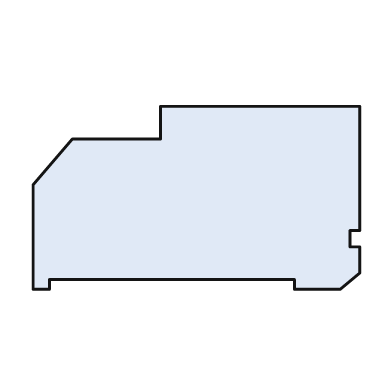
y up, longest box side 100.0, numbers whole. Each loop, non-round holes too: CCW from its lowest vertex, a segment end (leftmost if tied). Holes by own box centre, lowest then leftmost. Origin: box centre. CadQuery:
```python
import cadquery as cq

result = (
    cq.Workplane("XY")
    .moveTo(-50.0, -28.0)
    .lineTo(-45.0, -28.0)
    .lineTo(-45.0, -25.0)
    .lineTo(30.0, -25.0)
    .lineTo(30.0, -28.0)
    .lineTo(44.0, -28.0)
    .lineTo(50.0, -23.0)
    .lineTo(50.0, -15.0)
    .lineTo(47.0, -15.0)
    .lineTo(47.0, -10.0)
    .lineTo(50.0, -10.0)
    .lineTo(50.0, 28.0)
    .lineTo(-11.0, 28.0)
    .lineTo(-11.0, 18.0)
    .lineTo(-38.0, 18.0)
    .lineTo(-50.0, 4.0)
    .close()
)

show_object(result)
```